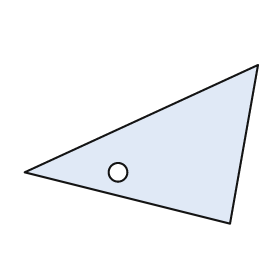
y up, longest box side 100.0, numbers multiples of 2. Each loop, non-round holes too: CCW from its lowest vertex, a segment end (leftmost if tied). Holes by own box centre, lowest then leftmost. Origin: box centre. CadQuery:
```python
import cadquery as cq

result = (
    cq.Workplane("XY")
    .moveTo(38.0, -34.0)
    .lineTo(50.0, 34.0)
    .lineTo(-50.0, -12.0)
    .close()
    .moveTo(-10.0, -12.0)
    .circle(4.0)
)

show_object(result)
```